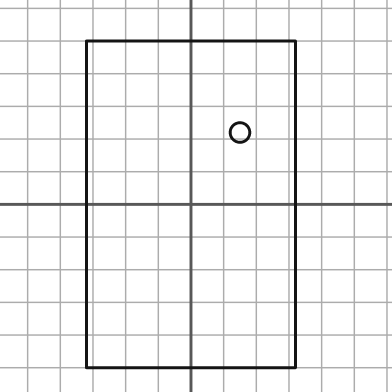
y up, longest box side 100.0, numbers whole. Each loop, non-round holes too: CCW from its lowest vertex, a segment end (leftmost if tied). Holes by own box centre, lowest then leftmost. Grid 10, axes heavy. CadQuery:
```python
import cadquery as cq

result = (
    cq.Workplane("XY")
    .moveTo(-32.0, -50.0)
    .lineTo(32.0, -50.0)
    .lineTo(32.0, 50.0)
    .lineTo(-32.0, 50.0)
    .close()
    .moveTo(15.0, 22.0)
    .circle(3.0)
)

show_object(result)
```